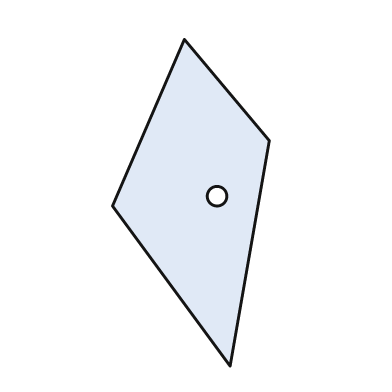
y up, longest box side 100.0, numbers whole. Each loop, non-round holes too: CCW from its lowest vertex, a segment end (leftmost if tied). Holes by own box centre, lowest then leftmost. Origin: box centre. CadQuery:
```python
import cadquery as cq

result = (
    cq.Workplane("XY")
    .moveTo(12.0, -50.0)
    .lineTo(24.0, 19.0)
    .lineTo(-2.0, 50.0)
    .lineTo(-24.0, -1.0)
    .close()
    .moveTo(8.0, 2.0)
    .circle(3.0)
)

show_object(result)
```